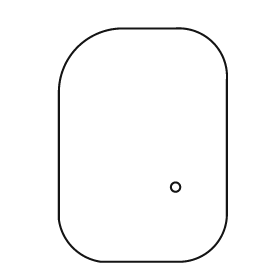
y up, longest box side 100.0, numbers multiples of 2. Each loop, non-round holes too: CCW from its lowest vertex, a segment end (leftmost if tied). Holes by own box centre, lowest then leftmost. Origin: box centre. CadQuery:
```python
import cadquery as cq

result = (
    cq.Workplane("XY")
    .moveTo(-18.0, -50.0)
    .lineTo(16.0, -50.0)
    .threePointArc((30.0, -44.0), (36.0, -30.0))
    .lineTo(36.0, 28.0)
    .threePointArc((30.0, 44.0), (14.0, 50.0))
    .lineTo(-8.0, 50.0)
    .threePointArc((-28.0, 42.0), (-36.0, 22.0))
    .lineTo(-36.0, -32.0)
    .threePointArc((-30.0, -44.0), (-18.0, -50.0))
    .close()
    .moveTo(14.0, -18.0)
    .circle(2.0)
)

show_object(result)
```